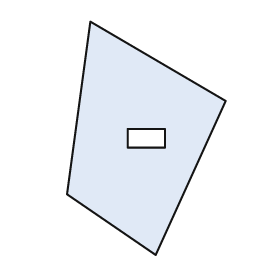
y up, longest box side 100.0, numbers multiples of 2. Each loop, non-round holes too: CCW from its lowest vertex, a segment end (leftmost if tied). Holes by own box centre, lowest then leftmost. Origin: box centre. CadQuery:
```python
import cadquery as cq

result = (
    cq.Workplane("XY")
    .moveTo(4.0, -50.0)
    .lineTo(34.0, 16.0)
    .lineTo(-24.0, 50.0)
    .lineTo(-34.0, -24.0)
    .close()
    .moveTo(-8.0, -4.0)
    .lineTo(8.0, -4.0)
    .lineTo(8.0, 4.0)
    .lineTo(-8.0, 4.0)
    .close()
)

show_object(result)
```